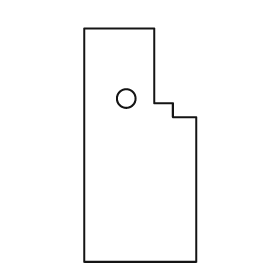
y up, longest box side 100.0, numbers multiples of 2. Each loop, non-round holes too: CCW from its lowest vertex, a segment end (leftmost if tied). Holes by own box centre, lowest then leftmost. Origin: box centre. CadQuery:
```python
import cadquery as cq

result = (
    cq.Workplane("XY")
    .moveTo(-24.0, -50.0)
    .lineTo(24.0, -50.0)
    .lineTo(24.0, 12.0)
    .lineTo(14.0, 12.0)
    .lineTo(14.0, 18.0)
    .lineTo(6.0, 18.0)
    .lineTo(6.0, 50.0)
    .lineTo(-24.0, 50.0)
    .close()
    .moveTo(-6.0, 20.0)
    .circle(4.0)
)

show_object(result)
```